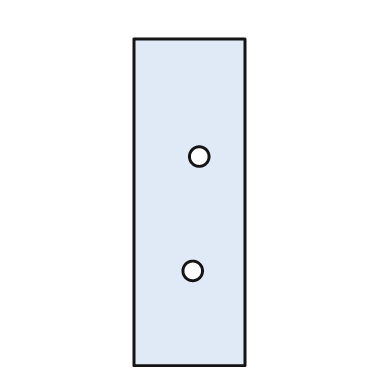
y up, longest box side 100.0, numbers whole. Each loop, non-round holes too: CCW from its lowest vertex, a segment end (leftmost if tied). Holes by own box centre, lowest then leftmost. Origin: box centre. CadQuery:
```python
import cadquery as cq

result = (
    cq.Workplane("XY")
    .moveTo(-17.0, -50.0)
    .lineTo(17.0, -50.0)
    .lineTo(17.0, 50.0)
    .lineTo(-17.0, 50.0)
    .close()
    .moveTo(1.0, -21.0)
    .circle(3.0)
    .moveTo(3.0, 14.0)
    .circle(3.0)
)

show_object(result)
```